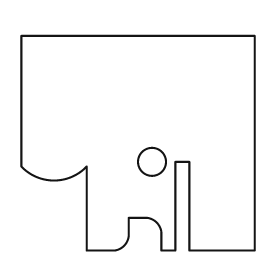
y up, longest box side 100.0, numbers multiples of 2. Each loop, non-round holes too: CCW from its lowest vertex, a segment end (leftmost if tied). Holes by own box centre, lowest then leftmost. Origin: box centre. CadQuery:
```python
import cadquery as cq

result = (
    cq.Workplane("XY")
    .moveTo(-22.0, -46.0)
    .lineTo(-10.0, -46.0)
    .threePointArc((-6.0, -44.0), (-4.0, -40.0))
    .lineTo(-4.0, -32.0)
    .lineTo(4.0, -32.0)
    .threePointArc((8.0, -34.0), (10.0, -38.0))
    .lineTo(10.0, -46.0)
    .lineTo(16.0, -46.0)
    .lineTo(16.0, -8.0)
    .lineTo(22.0, -8.0)
    .lineTo(22.0, -46.0)
    .lineTo(50.0, -46.0)
    .lineTo(50.0, 46.0)
    .lineTo(-50.0, 46.0)
    .lineTo(-50.0, -10.0)
    .threePointArc((-36.0, -16.0), (-22.0, -10.0))
    .close()
    .moveTo(6.0, -8.0)
    .circle(6.0)
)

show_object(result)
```